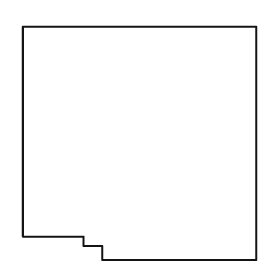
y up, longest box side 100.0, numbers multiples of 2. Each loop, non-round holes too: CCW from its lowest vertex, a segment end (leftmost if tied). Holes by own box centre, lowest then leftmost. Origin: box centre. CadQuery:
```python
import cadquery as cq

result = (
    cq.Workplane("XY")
    .moveTo(-16.0, -50.0)
    .lineTo(50.0, -50.0)
    .lineTo(50.0, 50.0)
    .lineTo(-50.0, 50.0)
    .lineTo(-50.0, -40.0)
    .lineTo(-24.0, -40.0)
    .lineTo(-24.0, -44.0)
    .lineTo(-16.0, -44.0)
    .close()
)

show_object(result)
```